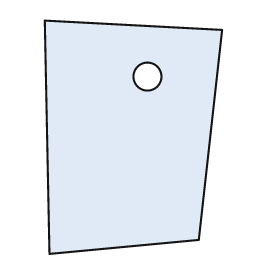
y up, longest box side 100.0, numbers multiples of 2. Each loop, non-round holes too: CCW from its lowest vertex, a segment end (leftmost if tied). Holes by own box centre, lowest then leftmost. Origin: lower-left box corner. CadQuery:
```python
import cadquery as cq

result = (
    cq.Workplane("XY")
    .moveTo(2.0, 0.0)
    .lineTo(66.0, 6.0)
    .lineTo(76.0, 96.0)
    .lineTo(0.0, 100.0)
    .close()
    .moveTo(44.0, 76.0)
    .circle(6.0)
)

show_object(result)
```